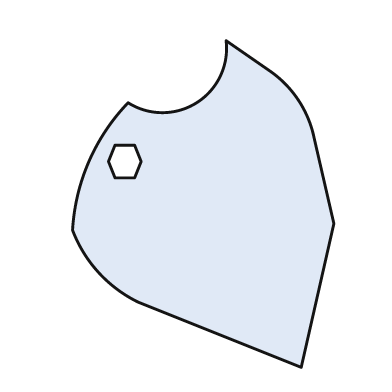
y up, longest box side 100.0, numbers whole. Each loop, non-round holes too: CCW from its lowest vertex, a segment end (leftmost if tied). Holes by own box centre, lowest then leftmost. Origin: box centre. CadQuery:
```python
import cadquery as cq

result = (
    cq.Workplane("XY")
    .moveTo(30.0, -50.0)
    .lineTo(40.0, -6.0)
    .lineTo(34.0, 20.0)
    .threePointArc((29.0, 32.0), (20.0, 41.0))
    .lineTo(7.0, 50.0)
    .threePointArc((-2.0, 31.0), (-23.0, 31.0))
    .threePointArc((-35.0, 13.0), (-40.0, -8.0))
    .threePointArc((-32.0, -21.0), (-20.0, -30.0))
    .close()
    .moveTo(-27.0, 8.0)
    .lineTo(-21.0, 8.0)
    .lineTo(-19.0, 13.0)
    .lineTo(-21.0, 18.0)
    .lineTo(-27.0, 18.0)
    .lineTo(-29.0, 13.0)
    .close()
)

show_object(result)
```